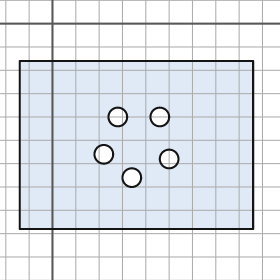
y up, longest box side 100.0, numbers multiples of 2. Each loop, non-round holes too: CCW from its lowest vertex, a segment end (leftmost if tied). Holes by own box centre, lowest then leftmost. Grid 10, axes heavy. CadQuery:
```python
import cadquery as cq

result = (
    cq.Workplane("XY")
    .moveTo(-14.0, -88.0)
    .lineTo(86.0, -88.0)
    .lineTo(86.0, -16.0)
    .lineTo(-14.0, -16.0)
    .close()
    .moveTo(34.0, -66.0)
    .circle(4.0)
    .moveTo(50.0, -58.0)
    .circle(4.0)
    .moveTo(22.0, -56.0)
    .circle(4.0)
    .moveTo(28.0, -40.0)
    .circle(4.0)
    .moveTo(46.0, -40.0)
    .circle(4.0)
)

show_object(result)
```